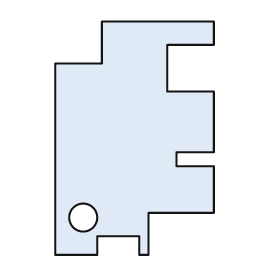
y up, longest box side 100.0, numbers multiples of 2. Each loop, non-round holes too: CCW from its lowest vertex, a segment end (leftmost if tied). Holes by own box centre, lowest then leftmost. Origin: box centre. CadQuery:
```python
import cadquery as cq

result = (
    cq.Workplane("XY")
    .moveTo(-34.0, -50.0)
    .lineTo(-16.0, -50.0)
    .lineTo(-16.0, -42.0)
    .lineTo(2.0, -42.0)
    .lineTo(2.0, -50.0)
    .lineTo(6.0, -50.0)
    .lineTo(6.0, -32.0)
    .lineTo(34.0, -32.0)
    .lineTo(34.0, -12.0)
    .lineTo(18.0, -12.0)
    .lineTo(18.0, -6.0)
    .lineTo(34.0, -6.0)
    .lineTo(34.0, 20.0)
    .lineTo(14.0, 20.0)
    .lineTo(14.0, 40.0)
    .lineTo(34.0, 40.0)
    .lineTo(34.0, 50.0)
    .lineTo(-14.0, 50.0)
    .lineTo(-14.0, 32.0)
    .lineTo(-34.0, 32.0)
    .close()
    .moveTo(-22.0, -34.0)
    .circle(6.0)
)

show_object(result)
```